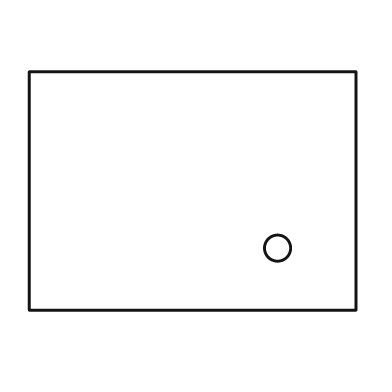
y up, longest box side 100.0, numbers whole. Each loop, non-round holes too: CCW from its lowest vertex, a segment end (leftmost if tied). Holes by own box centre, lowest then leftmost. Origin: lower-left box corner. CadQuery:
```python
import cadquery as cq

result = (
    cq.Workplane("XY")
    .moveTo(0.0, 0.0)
    .lineTo(100.0, 0.0)
    .lineTo(100.0, 73.0)
    .lineTo(0.0, 73.0)
    .close()
    .moveTo(76.0, 19.0)
    .circle(4.0)
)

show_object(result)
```